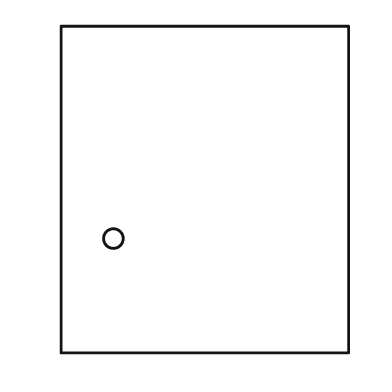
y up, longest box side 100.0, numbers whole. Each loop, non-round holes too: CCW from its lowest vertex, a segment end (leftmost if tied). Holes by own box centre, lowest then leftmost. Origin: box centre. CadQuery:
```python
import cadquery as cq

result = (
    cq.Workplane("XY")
    .moveTo(-44.0, -50.0)
    .lineTo(44.0, -50.0)
    .lineTo(44.0, 50.0)
    .lineTo(-44.0, 50.0)
    .close()
    .moveTo(-28.0, -15.0)
    .circle(3.0)
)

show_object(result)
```